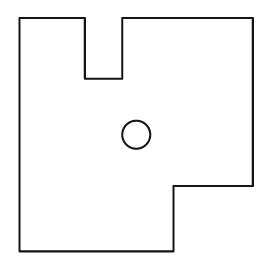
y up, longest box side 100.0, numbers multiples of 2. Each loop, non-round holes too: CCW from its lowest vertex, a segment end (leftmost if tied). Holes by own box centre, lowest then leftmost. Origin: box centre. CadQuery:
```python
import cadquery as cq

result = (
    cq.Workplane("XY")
    .moveTo(-50.0, -50.0)
    .lineTo(16.0, -50.0)
    .lineTo(16.0, -22.0)
    .lineTo(50.0, -22.0)
    .lineTo(50.0, 50.0)
    .lineTo(-6.0, 50.0)
    .lineTo(-6.0, 24.0)
    .lineTo(-22.0, 24.0)
    .lineTo(-22.0, 50.0)
    .lineTo(-50.0, 50.0)
    .close()
    .moveTo(0.0, 0.0)
    .circle(6.0)
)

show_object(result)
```